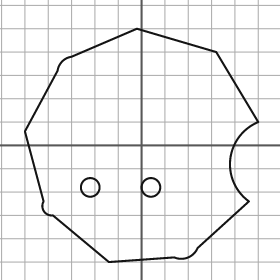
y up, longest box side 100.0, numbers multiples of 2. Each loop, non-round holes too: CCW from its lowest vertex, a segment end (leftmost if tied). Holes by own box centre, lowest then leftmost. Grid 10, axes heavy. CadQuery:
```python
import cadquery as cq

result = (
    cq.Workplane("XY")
    .moveTo(-14.0, -50.0)
    .lineTo(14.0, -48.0)
    .threePointArc((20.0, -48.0), (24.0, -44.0))
    .lineTo(46.0, -24.0)
    .threePointArc((38.0, -6.0), (50.0, 10.0))
    .lineTo(32.0, 40.0)
    .lineTo(-2.0, 50.0)
    .lineTo(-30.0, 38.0)
    .threePointArc((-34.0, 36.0), (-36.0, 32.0))
    .lineTo(-50.0, 6.0)
    .lineTo(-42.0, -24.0)
    .threePointArc((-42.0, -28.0), (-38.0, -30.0))
    .close()
    .moveTo(-22.0, -18.0)
    .circle(4.0)
    .moveTo(4.0, -18.0)
    .circle(4.0)
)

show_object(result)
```